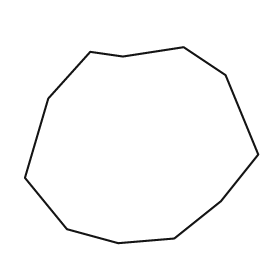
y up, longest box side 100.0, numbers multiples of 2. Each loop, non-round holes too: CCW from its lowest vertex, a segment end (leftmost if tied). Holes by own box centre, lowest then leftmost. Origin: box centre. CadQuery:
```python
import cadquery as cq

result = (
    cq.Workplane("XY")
    .moveTo(-10.0, -42.0)
    .lineTo(14.0, -40.0)
    .lineTo(34.0, -24.0)
    .lineTo(50.0, -4.0)
    .lineTo(36.0, 30.0)
    .lineTo(18.0, 42.0)
    .lineTo(-8.0, 38.0)
    .lineTo(-22.0, 40.0)
    .lineTo(-40.0, 20.0)
    .lineTo(-50.0, -14.0)
    .lineTo(-32.0, -36.0)
    .close()
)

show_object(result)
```